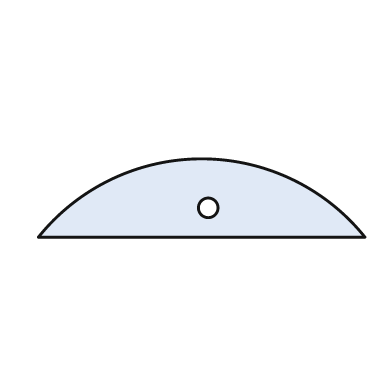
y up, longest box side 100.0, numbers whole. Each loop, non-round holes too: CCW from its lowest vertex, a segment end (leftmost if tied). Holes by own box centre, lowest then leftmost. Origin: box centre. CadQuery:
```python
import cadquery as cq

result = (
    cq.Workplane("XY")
    .moveTo(-50.0, -12.0)
    .lineTo(50.0, -12.0)
    .threePointArc((0.0, 12.0), (-50.0, -12.0))
    .close()
    .moveTo(2.0, -3.0)
    .circle(3.0)
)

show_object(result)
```